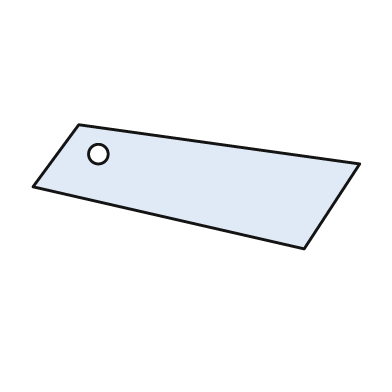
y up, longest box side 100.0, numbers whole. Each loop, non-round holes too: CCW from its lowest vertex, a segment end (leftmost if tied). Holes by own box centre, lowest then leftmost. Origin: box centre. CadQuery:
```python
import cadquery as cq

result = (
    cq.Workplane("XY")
    .moveTo(33.0, -19.0)
    .lineTo(50.0, 7.0)
    .lineTo(-36.0, 19.0)
    .lineTo(-50.0, 0.0)
    .close()
    .moveTo(-30.0, 10.0)
    .circle(3.0)
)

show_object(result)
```